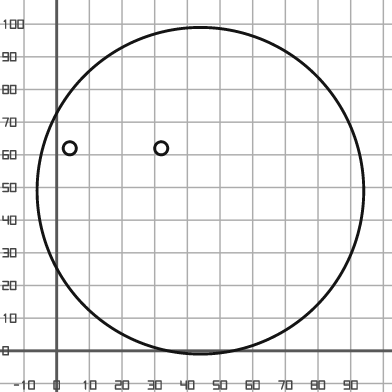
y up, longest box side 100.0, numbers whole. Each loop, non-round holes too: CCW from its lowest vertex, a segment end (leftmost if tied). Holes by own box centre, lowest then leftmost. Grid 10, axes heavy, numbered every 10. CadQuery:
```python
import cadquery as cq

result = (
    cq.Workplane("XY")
    .moveTo(44.0, 49.0)
    .circle(50.0)
    .moveTo(4.0, 62.0)
    .circle(2.0)
    .moveTo(32.0, 62.0)
    .circle(2.0)
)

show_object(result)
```